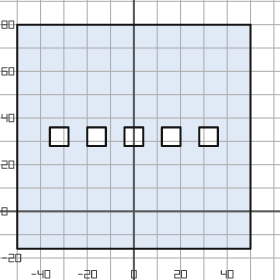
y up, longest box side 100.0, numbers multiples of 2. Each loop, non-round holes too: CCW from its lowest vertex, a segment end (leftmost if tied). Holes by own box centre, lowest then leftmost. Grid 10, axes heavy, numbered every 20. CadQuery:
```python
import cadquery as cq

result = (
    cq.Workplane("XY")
    .moveTo(-50.0, -16.0)
    .lineTo(50.0, -16.0)
    .lineTo(50.0, 80.0)
    .lineTo(-50.0, 80.0)
    .close()
    .moveTo(-36.0, 28.0)
    .lineTo(-28.0, 28.0)
    .lineTo(-28.0, 36.0)
    .lineTo(-36.0, 36.0)
    .close()
    .moveTo(-20.0, 28.0)
    .lineTo(-12.0, 28.0)
    .lineTo(-12.0, 36.0)
    .lineTo(-20.0, 36.0)
    .close()
    .moveTo(-4.0, 28.0)
    .lineTo(4.0, 28.0)
    .lineTo(4.0, 36.0)
    .lineTo(-4.0, 36.0)
    .close()
    .moveTo(12.0, 28.0)
    .lineTo(20.0, 28.0)
    .lineTo(20.0, 36.0)
    .lineTo(12.0, 36.0)
    .close()
    .moveTo(28.0, 28.0)
    .lineTo(36.0, 28.0)
    .lineTo(36.0, 36.0)
    .lineTo(28.0, 36.0)
    .close()
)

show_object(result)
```